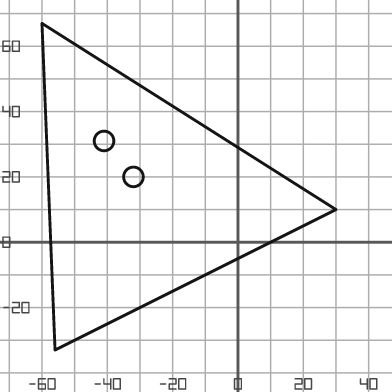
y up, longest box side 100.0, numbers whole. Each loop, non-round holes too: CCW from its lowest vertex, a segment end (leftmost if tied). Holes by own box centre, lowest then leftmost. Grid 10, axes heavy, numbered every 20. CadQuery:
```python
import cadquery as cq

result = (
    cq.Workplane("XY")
    .moveTo(-56.0, -33.0)
    .lineTo(30.0, 10.0)
    .lineTo(-60.0, 67.0)
    .close()
    .moveTo(-32.0, 20.0)
    .circle(3.0)
    .moveTo(-41.0, 31.0)
    .circle(3.0)
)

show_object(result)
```